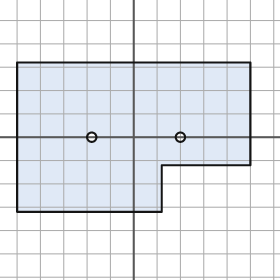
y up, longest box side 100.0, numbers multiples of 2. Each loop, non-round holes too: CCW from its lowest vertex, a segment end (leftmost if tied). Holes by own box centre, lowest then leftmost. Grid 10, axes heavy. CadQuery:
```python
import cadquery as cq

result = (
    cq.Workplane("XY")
    .moveTo(-50.0, -32.0)
    .lineTo(12.0, -32.0)
    .lineTo(12.0, -12.0)
    .lineTo(50.0, -12.0)
    .lineTo(50.0, 32.0)
    .lineTo(-50.0, 32.0)
    .close()
    .moveTo(-18.0, 0.0)
    .circle(2.0)
    .moveTo(20.0, 0.0)
    .circle(2.0)
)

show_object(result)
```